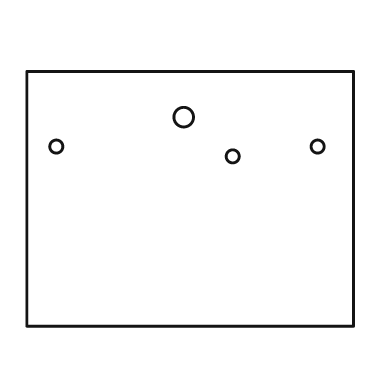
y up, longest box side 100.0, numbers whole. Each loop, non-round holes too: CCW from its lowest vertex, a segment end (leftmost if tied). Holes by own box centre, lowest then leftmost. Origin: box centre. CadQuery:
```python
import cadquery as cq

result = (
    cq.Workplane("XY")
    .moveTo(-50.0, -39.0)
    .lineTo(50.0, -39.0)
    .lineTo(50.0, 39.0)
    .lineTo(-50.0, 39.0)
    .close()
    .moveTo(13.0, 13.0)
    .circle(2.0)
    .moveTo(-41.0, 16.0)
    .circle(2.0)
    .moveTo(39.0, 16.0)
    .circle(2.0)
    .moveTo(-2.0, 25.0)
    .circle(3.0)
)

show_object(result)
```